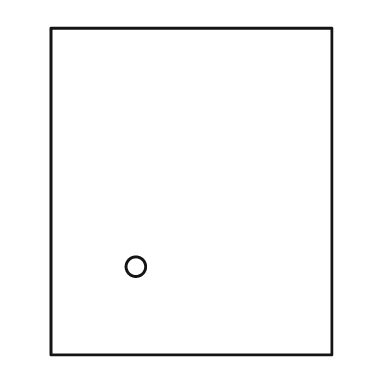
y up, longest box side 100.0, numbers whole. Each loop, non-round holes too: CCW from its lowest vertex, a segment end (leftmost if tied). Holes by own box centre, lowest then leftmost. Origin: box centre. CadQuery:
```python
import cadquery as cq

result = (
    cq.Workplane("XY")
    .moveTo(-43.0, -50.0)
    .lineTo(43.0, -50.0)
    .lineTo(43.0, 50.0)
    .lineTo(-43.0, 50.0)
    .close()
    .moveTo(-17.0, -23.0)
    .circle(3.0)
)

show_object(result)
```